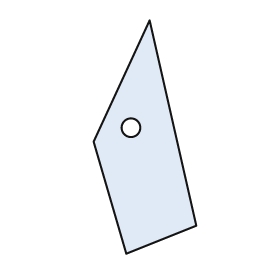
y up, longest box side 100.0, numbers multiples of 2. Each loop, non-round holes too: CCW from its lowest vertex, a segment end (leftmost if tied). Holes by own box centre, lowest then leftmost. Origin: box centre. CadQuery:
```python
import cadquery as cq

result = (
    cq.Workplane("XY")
    .moveTo(-8.0, -50.0)
    .lineTo(22.0, -38.0)
    .lineTo(2.0, 50.0)
    .lineTo(-22.0, -2.0)
    .close()
    .moveTo(-6.0, 4.0)
    .circle(4.0)
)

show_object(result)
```